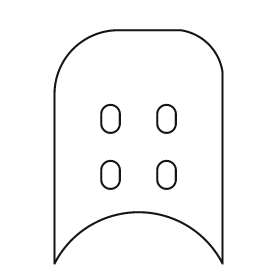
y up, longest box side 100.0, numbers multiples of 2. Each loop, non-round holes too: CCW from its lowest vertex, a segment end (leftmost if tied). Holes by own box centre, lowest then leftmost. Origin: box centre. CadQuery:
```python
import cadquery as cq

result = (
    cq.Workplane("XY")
    .moveTo(-36.0, -50.0)
    .threePointArc((0.0, -28.0), (36.0, -50.0))
    .lineTo(36.0, 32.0)
    .threePointArc((30.0, 44.0), (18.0, 50.0))
    .lineTo(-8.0, 50.0)
    .threePointArc((-28.0, 42.0), (-36.0, 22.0))
    .close()
    .moveTo(-16.0, -14.0)
    .threePointArc((-12.0, -18.0), (-8.0, -14.0))
    .lineTo(-8.0, -10.0)
    .threePointArc((-12.0, -6.0), (-16.0, -10.0))
    .close()
    .moveTo(8.0, -14.0)
    .threePointArc((12.0, -18.0), (16.0, -14.0))
    .lineTo(16.0, -10.0)
    .threePointArc((12.0, -6.0), (8.0, -10.0))
    .close()
    .moveTo(-16.0, 10.0)
    .threePointArc((-12.0, 6.0), (-8.0, 10.0))
    .lineTo(-8.0, 14.0)
    .threePointArc((-12.0, 18.0), (-16.0, 14.0))
    .close()
    .moveTo(8.0, 10.0)
    .threePointArc((12.0, 6.0), (16.0, 10.0))
    .lineTo(16.0, 14.0)
    .threePointArc((12.0, 18.0), (8.0, 14.0))
    .close()
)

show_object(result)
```